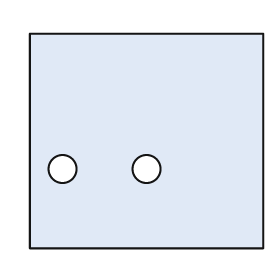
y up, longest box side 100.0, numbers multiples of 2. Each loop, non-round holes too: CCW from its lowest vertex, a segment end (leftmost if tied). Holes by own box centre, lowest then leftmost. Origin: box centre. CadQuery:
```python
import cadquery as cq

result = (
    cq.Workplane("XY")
    .moveTo(-50.0, -46.0)
    .lineTo(50.0, -46.0)
    .lineTo(50.0, 46.0)
    .lineTo(-50.0, 46.0)
    .close()
    .moveTo(-36.0, -12.0)
    .circle(6.0)
    .moveTo(0.0, -12.0)
    .circle(6.0)
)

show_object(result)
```